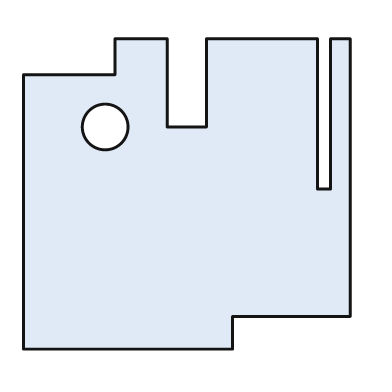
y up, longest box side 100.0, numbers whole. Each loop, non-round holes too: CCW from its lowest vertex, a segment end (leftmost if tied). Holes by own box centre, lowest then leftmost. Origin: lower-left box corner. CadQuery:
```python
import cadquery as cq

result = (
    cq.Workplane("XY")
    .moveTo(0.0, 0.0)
    .lineTo(64.0, 0.0)
    .lineTo(64.0, 10.0)
    .lineTo(100.0, 10.0)
    .lineTo(100.0, 95.0)
    .lineTo(94.0, 95.0)
    .lineTo(94.0, 49.0)
    .lineTo(90.0, 49.0)
    .lineTo(90.0, 95.0)
    .lineTo(56.0, 95.0)
    .lineTo(56.0, 68.0)
    .lineTo(44.0, 68.0)
    .lineTo(44.0, 95.0)
    .lineTo(28.0, 95.0)
    .lineTo(28.0, 84.0)
    .lineTo(0.0, 84.0)
    .close()
    .moveTo(25.0, 68.0)
    .circle(7.0)
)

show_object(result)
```